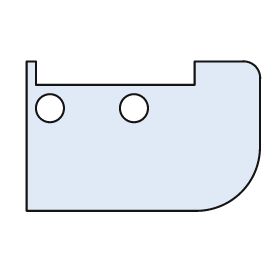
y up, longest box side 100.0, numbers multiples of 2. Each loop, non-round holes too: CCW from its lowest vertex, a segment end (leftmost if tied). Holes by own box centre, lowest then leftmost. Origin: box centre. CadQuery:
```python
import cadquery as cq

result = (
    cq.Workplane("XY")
    .moveTo(-50.0, -32.0)
    .lineTo(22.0, -32.0)
    .threePointArc((42.0, -24.0), (50.0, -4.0))
    .lineTo(50.0, 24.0)
    .threePointArc((48.0, 30.0), (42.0, 32.0))
    .lineTo(22.0, 32.0)
    .lineTo(22.0, 22.0)
    .lineTo(-46.0, 22.0)
    .lineTo(-46.0, 32.0)
    .lineTo(-50.0, 32.0)
    .close()
    .moveTo(-40.0, 12.0)
    .circle(6.0)
    .moveTo(-4.0, 12.0)
    .circle(6.0)
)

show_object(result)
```